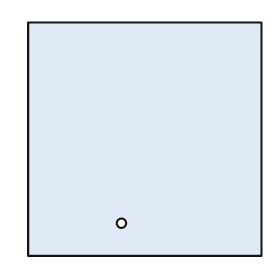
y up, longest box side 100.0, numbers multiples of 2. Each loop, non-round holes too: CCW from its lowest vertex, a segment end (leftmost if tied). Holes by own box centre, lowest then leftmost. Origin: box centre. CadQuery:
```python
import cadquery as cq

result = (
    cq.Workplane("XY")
    .moveTo(-50.0, -50.0)
    .lineTo(50.0, -50.0)
    .lineTo(50.0, 50.0)
    .lineTo(-50.0, 50.0)
    .close()
    .moveTo(-10.0, -36.0)
    .circle(2.0)
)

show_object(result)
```